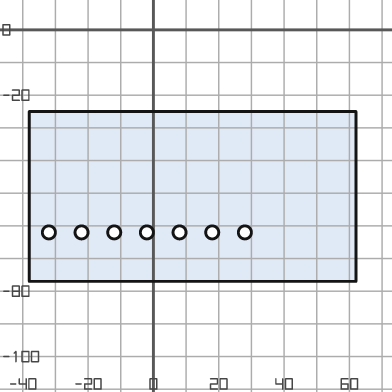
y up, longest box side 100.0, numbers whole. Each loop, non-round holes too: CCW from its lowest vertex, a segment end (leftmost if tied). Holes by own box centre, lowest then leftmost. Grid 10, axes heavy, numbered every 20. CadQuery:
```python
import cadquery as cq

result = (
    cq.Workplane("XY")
    .moveTo(-38.0, -77.0)
    .lineTo(62.0, -77.0)
    .lineTo(62.0, -25.0)
    .lineTo(-38.0, -25.0)
    .close()
    .moveTo(-32.0, -62.0)
    .circle(2.0)
    .moveTo(-22.0, -62.0)
    .circle(2.0)
    .moveTo(-12.0, -62.0)
    .circle(2.0)
    .moveTo(-2.0, -62.0)
    .circle(2.0)
    .moveTo(8.0, -62.0)
    .circle(2.0)
    .moveTo(18.0, -62.0)
    .circle(2.0)
    .moveTo(28.0, -62.0)
    .circle(2.0)
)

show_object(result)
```